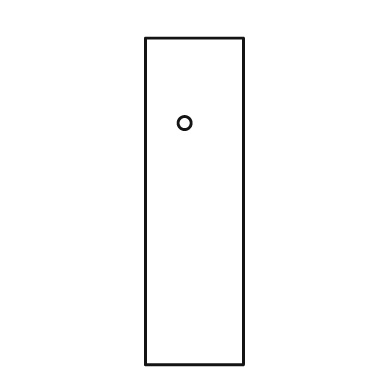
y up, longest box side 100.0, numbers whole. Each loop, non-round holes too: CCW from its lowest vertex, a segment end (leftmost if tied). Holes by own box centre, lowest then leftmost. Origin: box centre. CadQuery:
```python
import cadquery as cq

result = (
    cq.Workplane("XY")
    .moveTo(-15.0, -50.0)
    .lineTo(15.0, -50.0)
    .lineTo(15.0, 50.0)
    .lineTo(-15.0, 50.0)
    .close()
    .moveTo(-3.0, 24.0)
    .circle(2.0)
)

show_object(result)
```